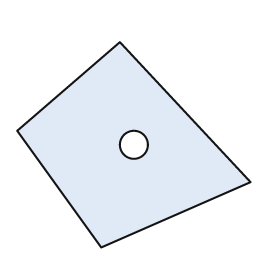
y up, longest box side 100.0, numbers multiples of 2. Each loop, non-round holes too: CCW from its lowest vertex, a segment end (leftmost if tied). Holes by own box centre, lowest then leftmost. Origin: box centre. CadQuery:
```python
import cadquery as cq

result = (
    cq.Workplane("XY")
    .moveTo(-14.0, -44.0)
    .lineTo(50.0, -16.0)
    .lineTo(-6.0, 44.0)
    .lineTo(-50.0, 6.0)
    .close()
    .moveTo(0.0, 0.0)
    .circle(6.0)
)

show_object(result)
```